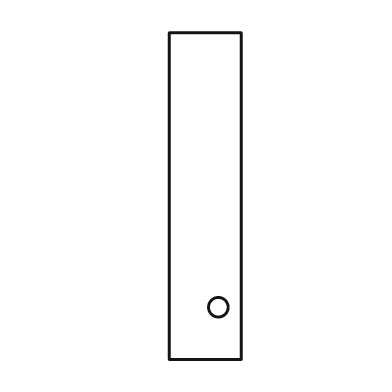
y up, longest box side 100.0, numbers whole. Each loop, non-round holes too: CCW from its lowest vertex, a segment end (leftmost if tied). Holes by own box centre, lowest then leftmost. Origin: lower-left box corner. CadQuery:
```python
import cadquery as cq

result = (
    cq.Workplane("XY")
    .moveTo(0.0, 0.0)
    .lineTo(22.0, 0.0)
    .lineTo(22.0, 100.0)
    .lineTo(0.0, 100.0)
    .close()
    .moveTo(15.0, 16.0)
    .circle(3.0)
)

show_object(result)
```